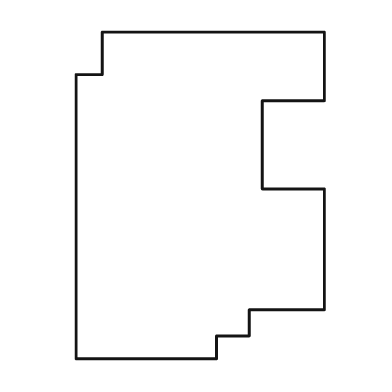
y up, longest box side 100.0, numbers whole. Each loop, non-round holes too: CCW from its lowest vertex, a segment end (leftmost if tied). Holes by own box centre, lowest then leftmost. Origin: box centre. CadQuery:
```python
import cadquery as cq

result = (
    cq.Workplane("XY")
    .moveTo(-38.0, -50.0)
    .lineTo(5.0, -50.0)
    .lineTo(5.0, -43.0)
    .lineTo(15.0, -43.0)
    .lineTo(15.0, -35.0)
    .lineTo(38.0, -35.0)
    .lineTo(38.0, 2.0)
    .lineTo(19.0, 2.0)
    .lineTo(19.0, 29.0)
    .lineTo(38.0, 29.0)
    .lineTo(38.0, 50.0)
    .lineTo(-30.0, 50.0)
    .lineTo(-30.0, 37.0)
    .lineTo(-38.0, 37.0)
    .close()
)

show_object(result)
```